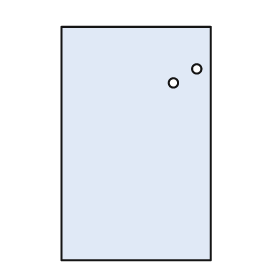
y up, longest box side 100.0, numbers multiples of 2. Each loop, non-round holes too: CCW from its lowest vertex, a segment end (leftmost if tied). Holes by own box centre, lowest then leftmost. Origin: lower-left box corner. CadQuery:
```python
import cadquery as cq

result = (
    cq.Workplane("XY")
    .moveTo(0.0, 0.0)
    .lineTo(64.0, 0.0)
    .lineTo(64.0, 100.0)
    .lineTo(0.0, 100.0)
    .close()
    .moveTo(48.0, 76.0)
    .circle(2.0)
    .moveTo(58.0, 82.0)
    .circle(2.0)
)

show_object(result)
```